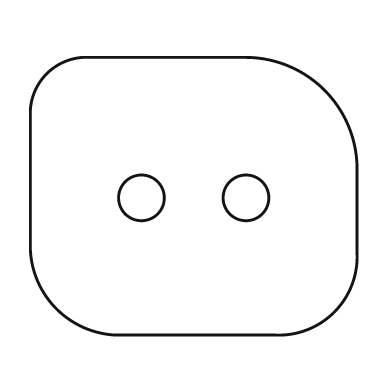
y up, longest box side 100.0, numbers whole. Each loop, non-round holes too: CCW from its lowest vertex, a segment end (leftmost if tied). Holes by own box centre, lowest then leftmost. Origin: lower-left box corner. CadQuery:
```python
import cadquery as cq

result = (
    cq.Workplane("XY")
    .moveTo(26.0, 0.0)
    .lineTo(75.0, 0.0)
    .threePointArc((93.0, 7.0), (100.0, 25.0))
    .lineTo(100.0, 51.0)
    .threePointArc((90.0, 75.0), (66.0, 85.0))
    .lineTo(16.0, 85.0)
    .threePointArc((5.0, 80.0), (0.0, 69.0))
    .lineTo(0.0, 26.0)
    .threePointArc((8.0, 8.0), (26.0, 0.0))
    .close()
    .moveTo(34.0, 42.0)
    .circle(7.0)
    .moveTo(66.0, 42.0)
    .circle(7.0)
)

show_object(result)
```